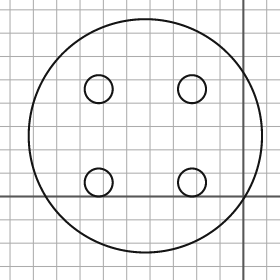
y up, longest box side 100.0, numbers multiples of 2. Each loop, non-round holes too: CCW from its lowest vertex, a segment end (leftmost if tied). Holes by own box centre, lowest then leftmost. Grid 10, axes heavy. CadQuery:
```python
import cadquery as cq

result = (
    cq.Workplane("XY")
    .moveTo(-42.0, 26.0)
    .circle(50.0)
    .moveTo(-62.0, 6.0)
    .circle(6.0)
    .moveTo(-22.0, 6.0)
    .circle(6.0)
    .moveTo(-62.0, 46.0)
    .circle(6.0)
    .moveTo(-22.0, 46.0)
    .circle(6.0)
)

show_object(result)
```